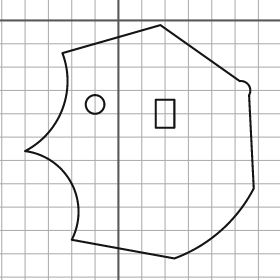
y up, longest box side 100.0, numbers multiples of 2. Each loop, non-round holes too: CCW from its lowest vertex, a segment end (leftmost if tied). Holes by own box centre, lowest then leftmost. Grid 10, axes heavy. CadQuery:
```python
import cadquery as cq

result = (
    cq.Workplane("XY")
    .moveTo(24.0, -102.0)
    .threePointArc((44.0, -90.0), (58.0, -72.0))
    .lineTo(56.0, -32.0)
    .threePointArc((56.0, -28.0), (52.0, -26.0))
    .lineTo(18.0, -2.0)
    .lineTo(-24.0, -14.0)
    .threePointArc((-24.0, -38.0), (-40.0, -56.0))
    .threePointArc((-20.0, -70.0), (-20.0, -94.0))
    .close()
    .moveTo(16.0, -46.0)
    .lineTo(24.0, -46.0)
    .lineTo(24.0, -34.0)
    .lineTo(16.0, -34.0)
    .close()
    .moveTo(-10.0, -36.0)
    .circle(4.0)
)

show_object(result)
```